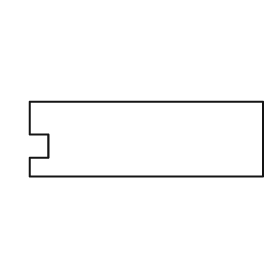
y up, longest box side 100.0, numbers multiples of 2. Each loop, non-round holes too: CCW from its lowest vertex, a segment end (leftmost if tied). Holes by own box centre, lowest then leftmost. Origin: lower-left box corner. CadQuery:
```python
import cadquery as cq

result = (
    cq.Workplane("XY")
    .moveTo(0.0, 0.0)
    .lineTo(100.0, 0.0)
    .lineTo(100.0, 32.0)
    .lineTo(0.0, 32.0)
    .lineTo(0.0, 18.0)
    .lineTo(8.0, 18.0)
    .lineTo(8.0, 8.0)
    .lineTo(0.0, 8.0)
    .close()
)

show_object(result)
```